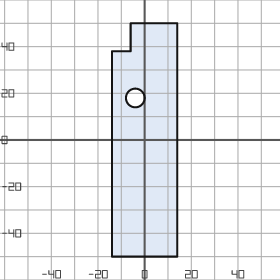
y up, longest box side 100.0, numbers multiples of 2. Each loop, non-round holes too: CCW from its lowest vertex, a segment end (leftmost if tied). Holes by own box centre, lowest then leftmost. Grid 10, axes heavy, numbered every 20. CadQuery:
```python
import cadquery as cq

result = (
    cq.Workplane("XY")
    .moveTo(-14.0, -50.0)
    .lineTo(14.0, -50.0)
    .lineTo(14.0, 50.0)
    .lineTo(-6.0, 50.0)
    .lineTo(-6.0, 38.0)
    .lineTo(-14.0, 38.0)
    .close()
    .moveTo(-4.0, 18.0)
    .circle(4.0)
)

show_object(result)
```